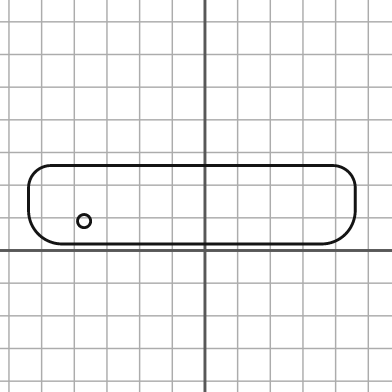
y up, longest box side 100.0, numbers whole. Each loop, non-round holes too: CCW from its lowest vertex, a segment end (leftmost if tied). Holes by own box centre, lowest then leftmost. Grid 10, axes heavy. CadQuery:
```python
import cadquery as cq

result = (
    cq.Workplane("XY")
    .moveTo(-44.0, 2.0)
    .lineTo(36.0, 2.0)
    .threePointArc((43.0, 5.0), (46.0, 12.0))
    .lineTo(46.0, 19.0)
    .threePointArc((44.0, 24.0), (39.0, 26.0))
    .lineTo(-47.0, 26.0)
    .threePointArc((-52.0, 24.0), (-54.0, 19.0))
    .lineTo(-54.0, 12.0)
    .threePointArc((-51.0, 5.0), (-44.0, 2.0))
    .close()
    .moveTo(-37.0, 9.0)
    .circle(2.0)
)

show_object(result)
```